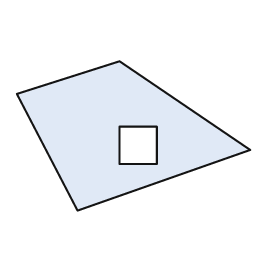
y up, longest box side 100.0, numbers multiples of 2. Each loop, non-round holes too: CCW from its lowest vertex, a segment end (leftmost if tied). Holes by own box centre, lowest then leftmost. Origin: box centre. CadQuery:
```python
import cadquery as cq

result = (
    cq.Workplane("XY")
    .moveTo(-24.0, -32.0)
    .lineTo(50.0, -6.0)
    .lineTo(-6.0, 32.0)
    .lineTo(-50.0, 18.0)
    .close()
    .moveTo(-6.0, -12.0)
    .lineTo(10.0, -12.0)
    .lineTo(10.0, 4.0)
    .lineTo(-6.0, 4.0)
    .close()
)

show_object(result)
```